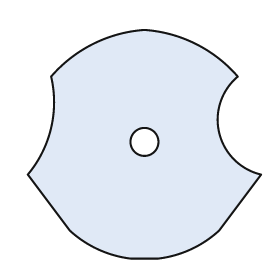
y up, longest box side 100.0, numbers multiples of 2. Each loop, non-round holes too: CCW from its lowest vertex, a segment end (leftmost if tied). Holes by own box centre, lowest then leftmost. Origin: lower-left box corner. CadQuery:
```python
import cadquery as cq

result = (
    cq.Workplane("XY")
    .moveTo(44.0, 0.0)
    .lineTo(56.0, 0.0)
    .threePointArc((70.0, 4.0), (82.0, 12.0))
    .lineTo(100.0, 36.0)
    .threePointArc((82.0, 54.0), (90.0, 78.0))
    .threePointArc((72.0, 92.0), (50.0, 98.0))
    .threePointArc((28.0, 92.0), (10.0, 78.0))
    .threePointArc((10.0, 56.0), (0.0, 36.0))
    .lineTo(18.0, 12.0)
    .threePointArc((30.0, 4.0), (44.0, 0.0))
    .close()
    .moveTo(50.0, 50.0)
    .circle(6.0)
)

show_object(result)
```